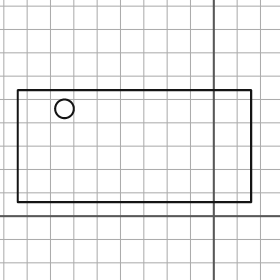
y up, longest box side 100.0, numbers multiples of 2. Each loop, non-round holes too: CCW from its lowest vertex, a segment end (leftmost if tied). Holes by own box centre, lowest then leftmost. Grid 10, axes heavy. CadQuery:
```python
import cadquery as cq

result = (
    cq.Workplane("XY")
    .moveTo(-84.0, 6.0)
    .lineTo(16.0, 6.0)
    .lineTo(16.0, 54.0)
    .lineTo(-84.0, 54.0)
    .close()
    .moveTo(-64.0, 46.0)
    .circle(4.0)
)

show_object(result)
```